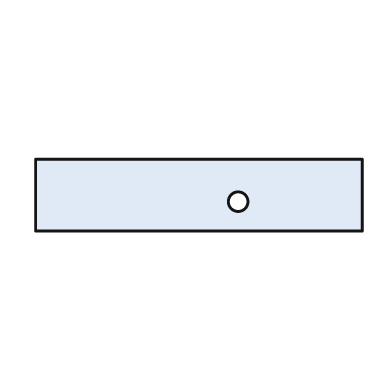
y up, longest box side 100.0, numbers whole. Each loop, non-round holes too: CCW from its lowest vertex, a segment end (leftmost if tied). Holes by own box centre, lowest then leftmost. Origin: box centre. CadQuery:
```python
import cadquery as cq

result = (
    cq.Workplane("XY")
    .moveTo(-50.0, -11.0)
    .lineTo(50.0, -11.0)
    .lineTo(50.0, 11.0)
    .lineTo(-50.0, 11.0)
    .close()
    .moveTo(12.0, -2.0)
    .circle(3.0)
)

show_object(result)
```